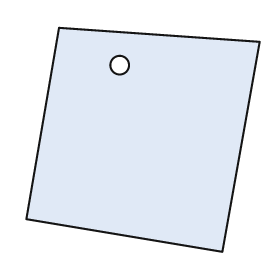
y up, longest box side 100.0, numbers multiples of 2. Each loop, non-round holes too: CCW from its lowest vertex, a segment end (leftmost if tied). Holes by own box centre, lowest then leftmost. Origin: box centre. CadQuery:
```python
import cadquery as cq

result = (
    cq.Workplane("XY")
    .moveTo(34.0, -48.0)
    .lineTo(50.0, 42.0)
    .lineTo(-36.0, 48.0)
    .lineTo(-50.0, -34.0)
    .close()
    .moveTo(-10.0, 32.0)
    .circle(4.0)
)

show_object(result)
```